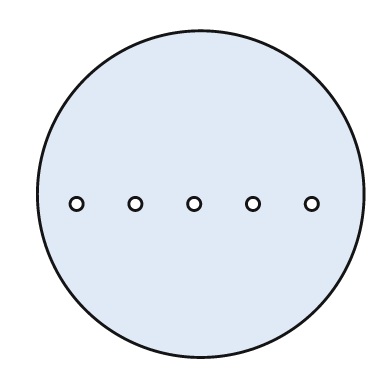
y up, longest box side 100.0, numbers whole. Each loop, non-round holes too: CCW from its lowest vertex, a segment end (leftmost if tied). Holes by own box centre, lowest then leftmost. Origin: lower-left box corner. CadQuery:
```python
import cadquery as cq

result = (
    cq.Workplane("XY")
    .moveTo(50.0, 50.0)
    .circle(50.0)
    .moveTo(12.0, 47.0)
    .circle(2.0)
    .moveTo(30.0, 47.0)
    .circle(2.0)
    .moveTo(48.0, 47.0)
    .circle(2.0)
    .moveTo(66.0, 47.0)
    .circle(2.0)
    .moveTo(84.0, 47.0)
    .circle(2.0)
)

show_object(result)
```